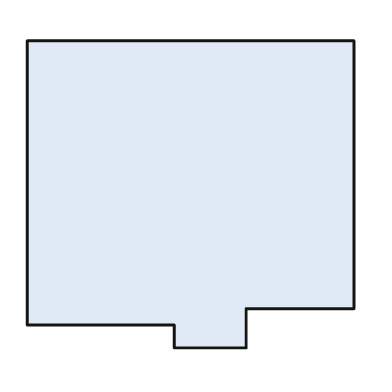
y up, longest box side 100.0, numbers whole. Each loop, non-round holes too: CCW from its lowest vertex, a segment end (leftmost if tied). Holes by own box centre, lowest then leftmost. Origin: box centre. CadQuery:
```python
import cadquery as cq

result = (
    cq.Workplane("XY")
    .moveTo(-5.0, -47.0)
    .lineTo(17.0, -47.0)
    .lineTo(17.0, -35.0)
    .lineTo(50.0, -35.0)
    .lineTo(50.0, 47.0)
    .lineTo(-50.0, 47.0)
    .lineTo(-50.0, -40.0)
    .lineTo(-5.0, -40.0)
    .close()
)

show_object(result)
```